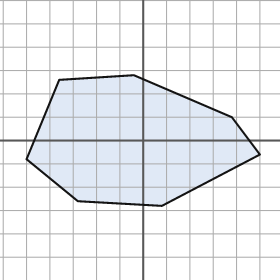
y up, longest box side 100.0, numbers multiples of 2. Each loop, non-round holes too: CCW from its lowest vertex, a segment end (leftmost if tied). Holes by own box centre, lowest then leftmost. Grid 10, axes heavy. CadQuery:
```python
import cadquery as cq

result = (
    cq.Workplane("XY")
    .moveTo(8.0, -28.0)
    .lineTo(50.0, -6.0)
    .lineTo(38.0, 10.0)
    .lineTo(-4.0, 28.0)
    .lineTo(-36.0, 26.0)
    .lineTo(-50.0, -8.0)
    .lineTo(-28.0, -26.0)
    .close()
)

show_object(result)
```